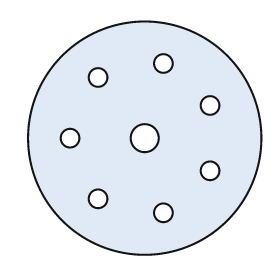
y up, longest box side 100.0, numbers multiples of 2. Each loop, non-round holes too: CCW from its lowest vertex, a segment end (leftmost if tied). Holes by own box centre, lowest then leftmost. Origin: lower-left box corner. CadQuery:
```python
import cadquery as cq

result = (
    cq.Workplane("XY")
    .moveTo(50.0, 50.0)
    .circle(50.0)
    .moveTo(58.0, 18.0)
    .circle(4.0)
    .moveTo(30.0, 24.0)
    .circle(4.0)
    .moveTo(78.0, 36.0)
    .circle(4.0)
    .moveTo(18.0, 50.0)
    .circle(4.0)
    .moveTo(50.0, 50.0)
    .circle(6.0)
    .moveTo(78.0, 64.0)
    .circle(4.0)
    .moveTo(30.0, 76.0)
    .circle(4.0)
    .moveTo(58.0, 82.0)
    .circle(4.0)
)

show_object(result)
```